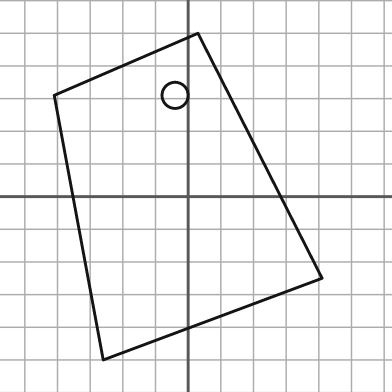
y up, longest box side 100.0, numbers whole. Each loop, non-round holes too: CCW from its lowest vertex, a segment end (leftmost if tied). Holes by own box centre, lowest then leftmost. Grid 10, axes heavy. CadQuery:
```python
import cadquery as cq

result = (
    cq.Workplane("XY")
    .moveTo(-26.0, -50.0)
    .lineTo(41.0, -25.0)
    .lineTo(3.0, 50.0)
    .lineTo(-41.0, 31.0)
    .close()
    .moveTo(-4.0, 31.0)
    .circle(4.0)
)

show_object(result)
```